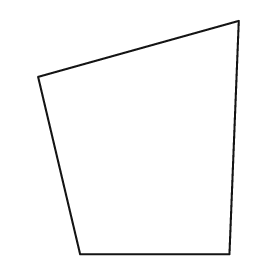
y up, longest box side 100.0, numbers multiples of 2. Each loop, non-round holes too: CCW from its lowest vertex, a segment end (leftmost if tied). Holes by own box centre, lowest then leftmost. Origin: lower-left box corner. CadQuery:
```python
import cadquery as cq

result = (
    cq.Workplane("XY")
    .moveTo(18.0, 0.0)
    .lineTo(82.0, 0.0)
    .lineTo(86.0, 100.0)
    .lineTo(0.0, 76.0)
    .close()
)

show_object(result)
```